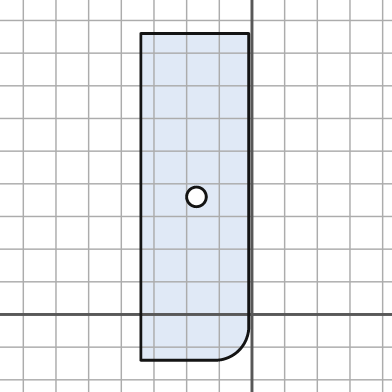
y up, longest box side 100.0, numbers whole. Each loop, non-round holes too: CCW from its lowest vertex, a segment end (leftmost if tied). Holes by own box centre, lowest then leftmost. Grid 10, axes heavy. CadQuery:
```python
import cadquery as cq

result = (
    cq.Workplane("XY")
    .moveTo(-34.0, -14.0)
    .lineTo(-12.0, -14.0)
    .threePointArc((-4.0, -11.0), (-1.0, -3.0))
    .lineTo(-1.0, 86.0)
    .lineTo(-34.0, 86.0)
    .close()
    .moveTo(-17.0, 36.0)
    .circle(3.0)
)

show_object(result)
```